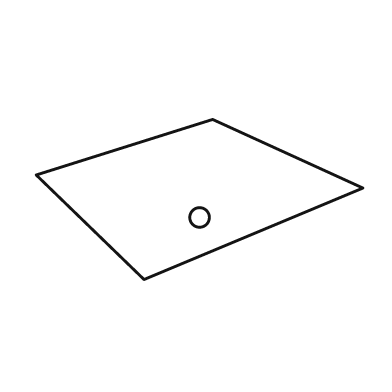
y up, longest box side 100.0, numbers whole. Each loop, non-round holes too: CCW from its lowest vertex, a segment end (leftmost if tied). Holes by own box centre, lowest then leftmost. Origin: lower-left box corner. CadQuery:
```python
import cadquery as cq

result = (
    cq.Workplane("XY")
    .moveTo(33.0, 0.0)
    .lineTo(100.0, 28.0)
    .lineTo(54.0, 49.0)
    .lineTo(0.0, 32.0)
    .close()
    .moveTo(50.0, 19.0)
    .circle(3.0)
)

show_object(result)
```